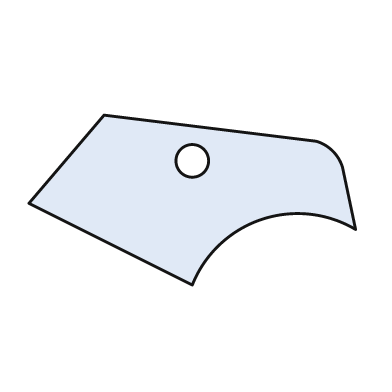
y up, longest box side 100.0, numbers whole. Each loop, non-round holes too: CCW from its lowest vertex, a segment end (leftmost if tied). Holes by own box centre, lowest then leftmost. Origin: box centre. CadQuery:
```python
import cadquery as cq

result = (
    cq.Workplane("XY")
    .moveTo(0.0, -26.0)
    .threePointArc((21.0, -6.0), (50.0, -9.0))
    .lineTo(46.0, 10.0)
    .threePointArc((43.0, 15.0), (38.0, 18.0))
    .lineTo(-27.0, 26.0)
    .lineTo(-50.0, -1.0)
    .close()
    .moveTo(0.0, 12.0)
    .circle(5.0)
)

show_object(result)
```